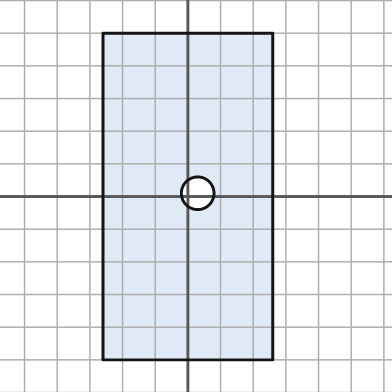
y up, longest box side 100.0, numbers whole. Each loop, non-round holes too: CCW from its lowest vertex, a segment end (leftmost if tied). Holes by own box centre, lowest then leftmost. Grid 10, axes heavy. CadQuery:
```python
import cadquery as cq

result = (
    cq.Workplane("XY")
    .moveTo(-26.0, -50.0)
    .lineTo(26.0, -50.0)
    .lineTo(26.0, 50.0)
    .lineTo(-26.0, 50.0)
    .close()
    .moveTo(3.0, 1.0)
    .circle(5.0)
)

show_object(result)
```